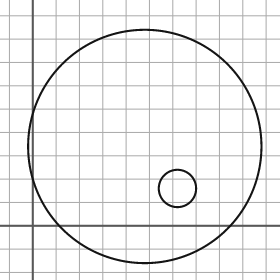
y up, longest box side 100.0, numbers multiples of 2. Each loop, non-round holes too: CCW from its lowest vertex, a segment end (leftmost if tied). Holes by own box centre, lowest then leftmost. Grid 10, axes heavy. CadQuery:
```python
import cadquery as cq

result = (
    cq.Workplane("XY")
    .moveTo(48.0, 34.0)
    .circle(50.0)
    .moveTo(62.0, 16.0)
    .circle(8.0)
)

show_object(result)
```